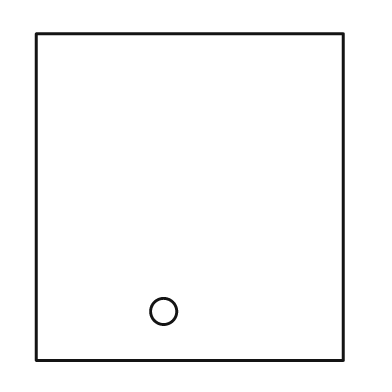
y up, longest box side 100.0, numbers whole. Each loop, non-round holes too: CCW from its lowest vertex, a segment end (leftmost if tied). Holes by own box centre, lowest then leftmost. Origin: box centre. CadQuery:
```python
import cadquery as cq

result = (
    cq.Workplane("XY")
    .moveTo(-47.0, -50.0)
    .lineTo(47.0, -50.0)
    .lineTo(47.0, 50.0)
    .lineTo(-47.0, 50.0)
    .close()
    .moveTo(-8.0, -35.0)
    .circle(4.0)
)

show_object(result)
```